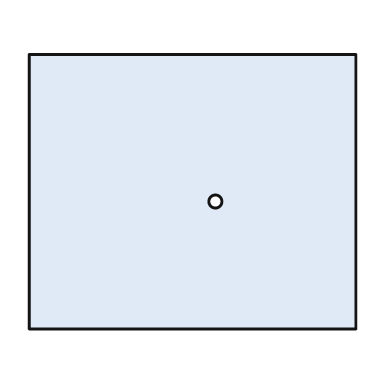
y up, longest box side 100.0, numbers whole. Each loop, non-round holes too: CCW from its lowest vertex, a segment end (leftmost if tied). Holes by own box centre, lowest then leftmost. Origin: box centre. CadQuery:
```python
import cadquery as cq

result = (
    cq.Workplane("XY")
    .moveTo(-50.0, -42.0)
    .lineTo(50.0, -42.0)
    .lineTo(50.0, 42.0)
    .lineTo(-50.0, 42.0)
    .close()
    .moveTo(7.0, -3.0)
    .circle(2.0)
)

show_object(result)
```